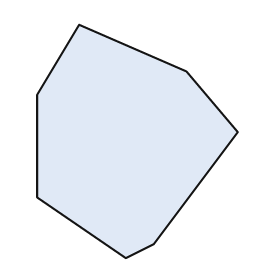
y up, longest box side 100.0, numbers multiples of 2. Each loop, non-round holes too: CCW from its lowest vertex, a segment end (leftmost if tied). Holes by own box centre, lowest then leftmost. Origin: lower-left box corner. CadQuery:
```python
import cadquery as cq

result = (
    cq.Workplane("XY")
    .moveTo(38.0, 0.0)
    .lineTo(50.0, 6.0)
    .lineTo(86.0, 54.0)
    .lineTo(64.0, 80.0)
    .lineTo(18.0, 100.0)
    .lineTo(0.0, 70.0)
    .lineTo(0.0, 26.0)
    .close()
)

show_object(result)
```